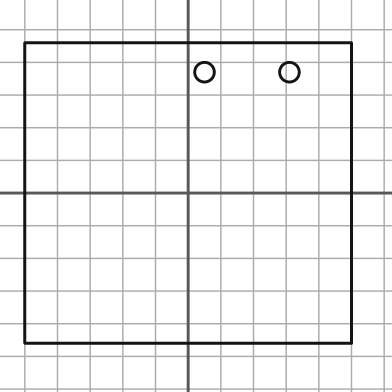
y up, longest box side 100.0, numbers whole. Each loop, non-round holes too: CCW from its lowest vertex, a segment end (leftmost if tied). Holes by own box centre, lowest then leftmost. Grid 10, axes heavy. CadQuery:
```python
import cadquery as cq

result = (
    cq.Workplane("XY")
    .moveTo(-50.0, -46.0)
    .lineTo(50.0, -46.0)
    .lineTo(50.0, 46.0)
    .lineTo(-50.0, 46.0)
    .close()
    .moveTo(5.0, 37.0)
    .circle(3.0)
    .moveTo(31.0, 37.0)
    .circle(3.0)
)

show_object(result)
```